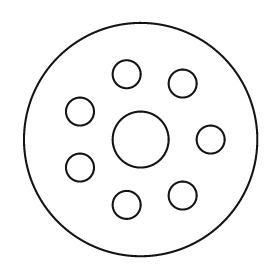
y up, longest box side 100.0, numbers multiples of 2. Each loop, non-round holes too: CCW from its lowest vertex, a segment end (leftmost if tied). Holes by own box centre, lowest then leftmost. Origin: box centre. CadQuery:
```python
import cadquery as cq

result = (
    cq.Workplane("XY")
    .moveTo(0.0, 0.0)
    .circle(50.0)
    .moveTo(-6.0, -28.0)
    .circle(6.0)
    .moveTo(18.0, -24.0)
    .circle(6.0)
    .moveTo(-26.0, -12.0)
    .circle(6.0)
    .moveTo(0.0, 0.0)
    .circle(12.0)
    .moveTo(30.0, 0.0)
    .circle(6.0)
    .moveTo(-26.0, 12.0)
    .circle(6.0)
    .moveTo(18.0, 24.0)
    .circle(6.0)
    .moveTo(-6.0, 28.0)
    .circle(6.0)
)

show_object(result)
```